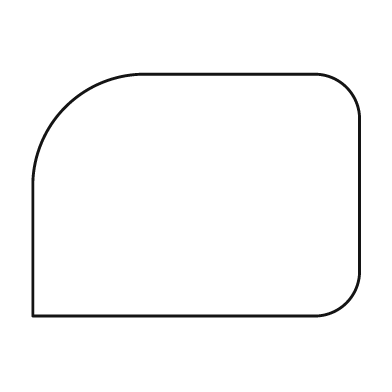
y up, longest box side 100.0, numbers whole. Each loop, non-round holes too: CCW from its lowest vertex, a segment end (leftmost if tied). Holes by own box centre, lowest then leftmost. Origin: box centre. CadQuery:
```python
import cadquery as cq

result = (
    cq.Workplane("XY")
    .moveTo(-50.0, -37.0)
    .lineTo(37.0, -37.0)
    .threePointArc((46.0, -33.0), (50.0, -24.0))
    .lineTo(50.0, 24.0)
    .threePointArc((46.0, 33.0), (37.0, 37.0))
    .lineTo(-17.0, 37.0)
    .threePointArc((-40.0, 27.0), (-50.0, 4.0))
    .close()
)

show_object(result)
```